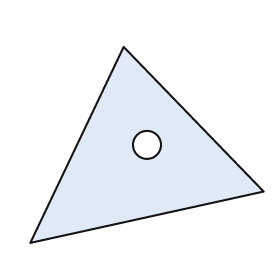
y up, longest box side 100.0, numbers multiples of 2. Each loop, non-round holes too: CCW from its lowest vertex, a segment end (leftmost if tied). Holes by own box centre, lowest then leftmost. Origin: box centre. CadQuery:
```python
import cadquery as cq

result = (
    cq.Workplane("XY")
    .moveTo(-50.0, -42.0)
    .lineTo(50.0, -20.0)
    .lineTo(-10.0, 42.0)
    .close()
    .moveTo(0.0, 0.0)
    .circle(6.0)
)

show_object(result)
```